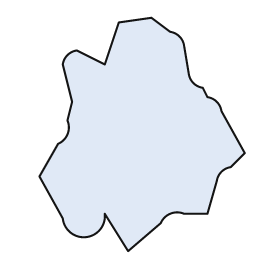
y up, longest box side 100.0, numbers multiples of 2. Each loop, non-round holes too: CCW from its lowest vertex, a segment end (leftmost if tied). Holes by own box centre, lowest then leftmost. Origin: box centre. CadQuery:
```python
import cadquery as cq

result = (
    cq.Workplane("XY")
    .moveTo(-6.0, -50.0)
    .lineTo(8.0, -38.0)
    .threePointArc((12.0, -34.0), (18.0, -34.0))
    .lineTo(28.0, -34.0)
    .lineTo(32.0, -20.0)
    .threePointArc((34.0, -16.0), (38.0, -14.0))
    .lineTo(44.0, -8.0)
    .lineTo(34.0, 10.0)
    .threePointArc((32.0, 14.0), (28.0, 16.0))
    .lineTo(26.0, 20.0)
    .threePointArc((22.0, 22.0), (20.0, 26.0))
    .lineTo(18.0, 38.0)
    .threePointArc((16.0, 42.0), (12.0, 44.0))
    .lineTo(4.0, 50.0)
    .lineTo(-10.0, 48.0)
    .lineTo(-16.0, 30.0)
    .lineTo(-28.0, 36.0)
    .threePointArc((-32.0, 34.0), (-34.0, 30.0))
    .lineTo(-30.0, 14.0)
    .lineTo(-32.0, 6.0)
    .threePointArc((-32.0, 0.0), (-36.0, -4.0))
    .lineTo(-44.0, -18.0)
    .lineTo(-34.0, -36.0)
    .threePointArc((-24.0, -44.0), (-16.0, -34.0))
    .close()
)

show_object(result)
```